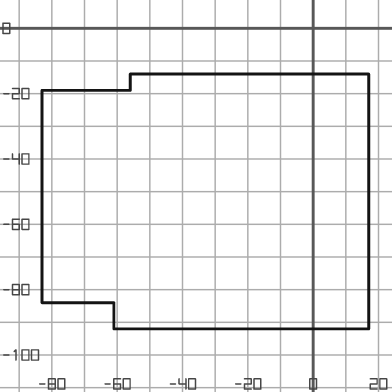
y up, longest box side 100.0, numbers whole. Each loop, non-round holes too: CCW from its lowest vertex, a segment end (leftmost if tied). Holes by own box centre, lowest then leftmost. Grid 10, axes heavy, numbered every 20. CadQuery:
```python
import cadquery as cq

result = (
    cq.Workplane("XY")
    .moveTo(-61.0, -92.0)
    .lineTo(17.0, -92.0)
    .lineTo(17.0, -14.0)
    .lineTo(-56.0, -14.0)
    .lineTo(-56.0, -19.0)
    .lineTo(-83.0, -19.0)
    .lineTo(-83.0, -84.0)
    .lineTo(-61.0, -84.0)
    .close()
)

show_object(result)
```